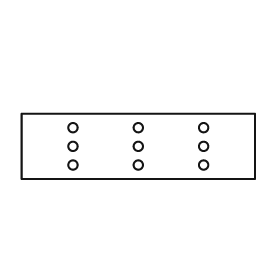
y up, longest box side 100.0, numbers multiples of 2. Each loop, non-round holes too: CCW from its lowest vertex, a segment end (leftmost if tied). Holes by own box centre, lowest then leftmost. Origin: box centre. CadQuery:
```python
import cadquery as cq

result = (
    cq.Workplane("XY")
    .moveTo(-50.0, -14.0)
    .lineTo(50.0, -14.0)
    .lineTo(50.0, 14.0)
    .lineTo(-50.0, 14.0)
    .close()
    .moveTo(-28.0, -8.0)
    .circle(2.0)
    .moveTo(0.0, -8.0)
    .circle(2.0)
    .moveTo(28.0, -8.0)
    .circle(2.0)
    .moveTo(-28.0, 0.0)
    .circle(2.0)
    .moveTo(0.0, 0.0)
    .circle(2.0)
    .moveTo(28.0, 0.0)
    .circle(2.0)
    .moveTo(-28.0, 8.0)
    .circle(2.0)
    .moveTo(0.0, 8.0)
    .circle(2.0)
    .moveTo(28.0, 8.0)
    .circle(2.0)
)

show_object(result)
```